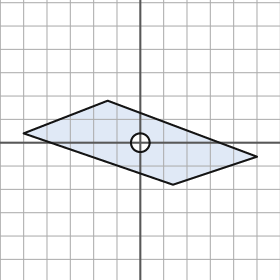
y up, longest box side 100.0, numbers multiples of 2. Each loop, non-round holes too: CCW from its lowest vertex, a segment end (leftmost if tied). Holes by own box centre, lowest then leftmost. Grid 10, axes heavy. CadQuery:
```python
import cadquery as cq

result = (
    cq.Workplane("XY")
    .moveTo(14.0, -18.0)
    .lineTo(50.0, -6.0)
    .lineTo(-14.0, 18.0)
    .lineTo(-50.0, 4.0)
    .close()
    .moveTo(0.0, 0.0)
    .circle(4.0)
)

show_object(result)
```